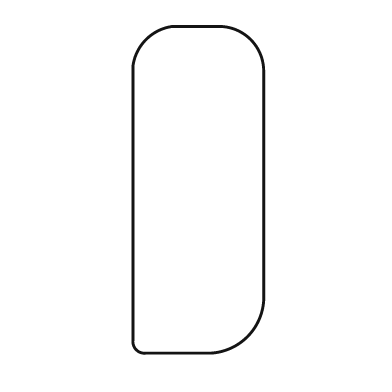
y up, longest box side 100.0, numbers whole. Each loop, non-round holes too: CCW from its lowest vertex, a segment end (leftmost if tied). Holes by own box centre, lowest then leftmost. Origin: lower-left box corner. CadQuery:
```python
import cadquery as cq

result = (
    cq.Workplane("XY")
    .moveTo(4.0, 0.0)
    .lineTo(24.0, 0.0)
    .threePointArc((35.0, 5.0), (40.0, 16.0))
    .lineTo(40.0, 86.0)
    .threePointArc((36.0, 96.0), (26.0, 100.0))
    .lineTo(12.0, 100.0)
    .threePointArc((4.0, 96.0), (0.0, 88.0))
    .lineTo(0.0, 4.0)
    .threePointArc((1.0, 1.0), (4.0, 0.0))
    .close()
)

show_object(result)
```